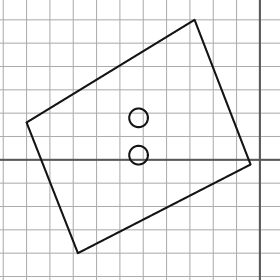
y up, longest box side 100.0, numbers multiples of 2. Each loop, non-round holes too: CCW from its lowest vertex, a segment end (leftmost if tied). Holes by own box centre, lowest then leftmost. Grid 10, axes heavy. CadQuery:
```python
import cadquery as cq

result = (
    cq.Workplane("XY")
    .moveTo(-78.0, -40.0)
    .lineTo(-4.0, -2.0)
    .lineTo(-28.0, 60.0)
    .lineTo(-100.0, 16.0)
    .close()
    .moveTo(-52.0, 2.0)
    .circle(4.0)
    .moveTo(-52.0, 18.0)
    .circle(4.0)
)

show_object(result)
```